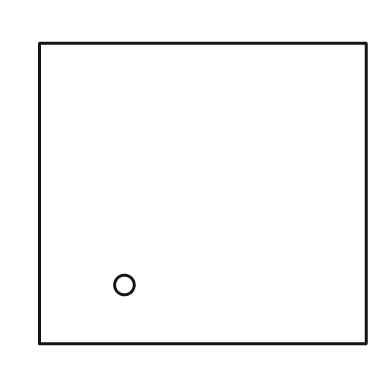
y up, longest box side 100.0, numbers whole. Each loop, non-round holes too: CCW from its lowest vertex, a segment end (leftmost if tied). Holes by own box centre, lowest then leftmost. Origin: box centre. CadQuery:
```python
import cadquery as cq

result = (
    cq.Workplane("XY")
    .moveTo(-50.0, -46.0)
    .lineTo(50.0, -46.0)
    .lineTo(50.0, 46.0)
    .lineTo(-50.0, 46.0)
    .close()
    .moveTo(-24.0, -28.0)
    .circle(3.0)
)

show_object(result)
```